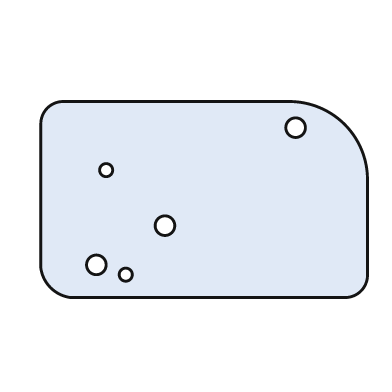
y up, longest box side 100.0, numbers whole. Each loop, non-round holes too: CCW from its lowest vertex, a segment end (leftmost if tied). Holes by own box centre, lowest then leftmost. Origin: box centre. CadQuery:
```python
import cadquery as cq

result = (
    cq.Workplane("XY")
    .moveTo(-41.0, -30.0)
    .lineTo(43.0, -30.0)
    .threePointArc((48.0, -28.0), (50.0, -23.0))
    .lineTo(50.0, 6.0)
    .threePointArc((43.0, 23.0), (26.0, 30.0))
    .lineTo(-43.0, 30.0)
    .threePointArc((-48.0, 28.0), (-50.0, 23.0))
    .lineTo(-50.0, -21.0)
    .threePointArc((-47.0, -27.0), (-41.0, -30.0))
    .close()
    .moveTo(-24.0, -23.0)
    .circle(2.0)
    .moveTo(-33.0, -20.0)
    .circle(3.0)
    .moveTo(-12.0, -8.0)
    .circle(3.0)
    .moveTo(-30.0, 9.0)
    .circle(2.0)
    .moveTo(28.0, 22.0)
    .circle(3.0)
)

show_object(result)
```